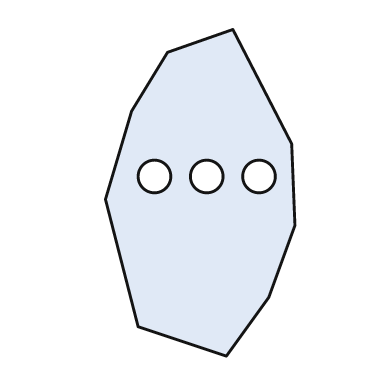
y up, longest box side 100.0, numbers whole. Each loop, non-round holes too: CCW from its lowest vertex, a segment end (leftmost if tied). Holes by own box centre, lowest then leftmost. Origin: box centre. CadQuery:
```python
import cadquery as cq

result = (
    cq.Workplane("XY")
    .moveTo(8.0, -50.0)
    .lineTo(21.0, -32.0)
    .lineTo(29.0, -10.0)
    .lineTo(28.0, 15.0)
    .lineTo(10.0, 50.0)
    .lineTo(-10.0, 43.0)
    .lineTo(-21.0, 25.0)
    .lineTo(-29.0, -2.0)
    .lineTo(-19.0, -41.0)
    .close()
    .moveTo(-14.0, 5.0)
    .circle(5.0)
    .moveTo(2.0, 5.0)
    .circle(5.0)
    .moveTo(18.0, 5.0)
    .circle(5.0)
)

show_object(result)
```